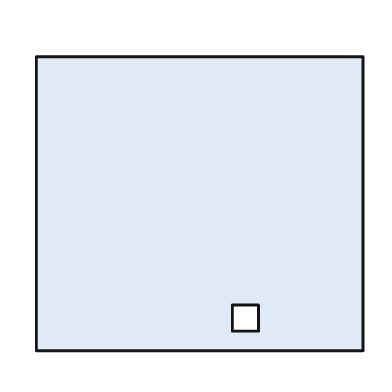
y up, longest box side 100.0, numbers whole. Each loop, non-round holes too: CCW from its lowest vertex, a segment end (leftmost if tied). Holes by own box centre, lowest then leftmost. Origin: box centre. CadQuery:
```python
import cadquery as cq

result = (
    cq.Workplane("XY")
    .moveTo(-50.0, -45.0)
    .lineTo(50.0, -45.0)
    .lineTo(50.0, 45.0)
    .lineTo(-50.0, 45.0)
    .close()
    .moveTo(10.0, -39.0)
    .lineTo(18.0, -39.0)
    .lineTo(18.0, -31.0)
    .lineTo(10.0, -31.0)
    .close()
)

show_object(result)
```